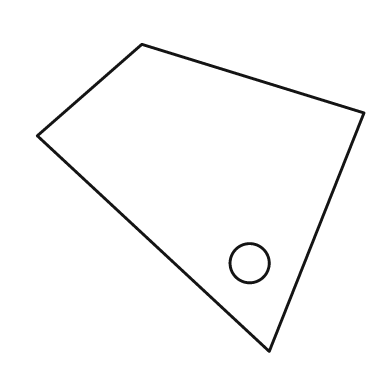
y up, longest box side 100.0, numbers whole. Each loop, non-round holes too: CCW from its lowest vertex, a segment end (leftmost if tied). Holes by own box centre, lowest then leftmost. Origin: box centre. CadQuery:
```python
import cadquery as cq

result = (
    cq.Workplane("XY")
    .moveTo(21.0, -47.0)
    .lineTo(50.0, 26.0)
    .lineTo(-18.0, 47.0)
    .lineTo(-50.0, 19.0)
    .close()
    .moveTo(15.0, -20.0)
    .circle(6.0)
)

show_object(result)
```